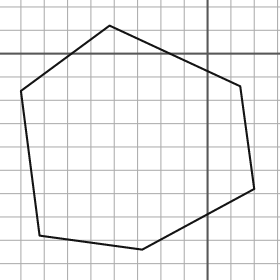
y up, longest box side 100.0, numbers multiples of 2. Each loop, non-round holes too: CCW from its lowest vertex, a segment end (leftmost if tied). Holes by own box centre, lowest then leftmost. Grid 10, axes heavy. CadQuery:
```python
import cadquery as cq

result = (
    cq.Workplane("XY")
    .moveTo(-28.0, -84.0)
    .lineTo(20.0, -58.0)
    .lineTo(14.0, -14.0)
    .lineTo(-42.0, 12.0)
    .lineTo(-80.0, -16.0)
    .lineTo(-72.0, -78.0)
    .close()
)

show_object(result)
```